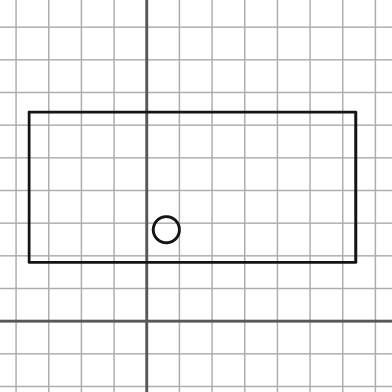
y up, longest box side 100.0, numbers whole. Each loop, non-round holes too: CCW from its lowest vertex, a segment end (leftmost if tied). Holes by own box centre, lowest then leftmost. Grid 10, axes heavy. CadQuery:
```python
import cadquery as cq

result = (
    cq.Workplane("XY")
    .moveTo(-36.0, 18.0)
    .lineTo(64.0, 18.0)
    .lineTo(64.0, 64.0)
    .lineTo(-36.0, 64.0)
    .close()
    .moveTo(6.0, 28.0)
    .circle(4.0)
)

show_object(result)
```